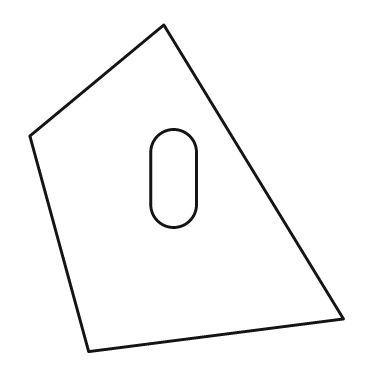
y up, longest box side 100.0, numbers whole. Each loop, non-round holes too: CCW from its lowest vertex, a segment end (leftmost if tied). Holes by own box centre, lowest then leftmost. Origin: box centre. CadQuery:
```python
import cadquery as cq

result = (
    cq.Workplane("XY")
    .moveTo(-30.0, -50.0)
    .lineTo(48.0, -40.0)
    .lineTo(-7.0, 50.0)
    .lineTo(-48.0, 16.0)
    .close()
    .moveTo(-11.0, -5.0)
    .threePointArc((-4.0, -12.0), (3.0, -5.0))
    .lineTo(3.0, 11.0)
    .threePointArc((-4.0, 18.0), (-11.0, 11.0))
    .close()
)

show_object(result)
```